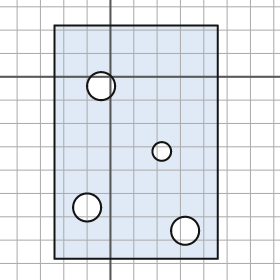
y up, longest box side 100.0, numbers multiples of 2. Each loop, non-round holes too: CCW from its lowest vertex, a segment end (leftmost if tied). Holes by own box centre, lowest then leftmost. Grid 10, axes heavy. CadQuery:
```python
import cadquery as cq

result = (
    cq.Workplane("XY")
    .moveTo(-24.0, -78.0)
    .lineTo(46.0, -78.0)
    .lineTo(46.0, 22.0)
    .lineTo(-24.0, 22.0)
    .close()
    .moveTo(32.0, -66.0)
    .circle(6.0)
    .moveTo(-10.0, -56.0)
    .circle(6.0)
    .moveTo(22.0, -32.0)
    .circle(4.0)
    .moveTo(-4.0, -4.0)
    .circle(6.0)
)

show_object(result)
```